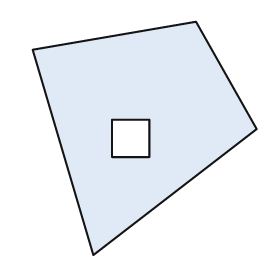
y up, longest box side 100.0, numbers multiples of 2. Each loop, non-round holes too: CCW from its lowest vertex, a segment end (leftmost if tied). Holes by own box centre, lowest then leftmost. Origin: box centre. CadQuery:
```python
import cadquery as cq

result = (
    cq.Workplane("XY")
    .moveTo(-22.0, -50.0)
    .lineTo(48.0, 4.0)
    .lineTo(22.0, 50.0)
    .lineTo(-48.0, 38.0)
    .close()
    .moveTo(-14.0, -8.0)
    .lineTo(2.0, -8.0)
    .lineTo(2.0, 8.0)
    .lineTo(-14.0, 8.0)
    .close()
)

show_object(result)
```